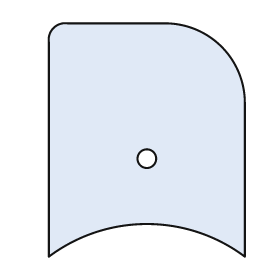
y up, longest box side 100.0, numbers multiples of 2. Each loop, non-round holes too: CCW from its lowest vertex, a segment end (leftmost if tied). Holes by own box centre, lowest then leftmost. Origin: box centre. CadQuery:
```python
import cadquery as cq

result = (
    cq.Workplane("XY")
    .moveTo(-42.0, -50.0)
    .threePointArc((0.0, -36.0), (42.0, -50.0))
    .lineTo(42.0, 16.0)
    .threePointArc((32.0, 40.0), (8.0, 50.0))
    .lineTo(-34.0, 50.0)
    .threePointArc((-40.0, 48.0), (-42.0, 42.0))
    .close()
    .moveTo(0.0, -8.0)
    .circle(4.0)
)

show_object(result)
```